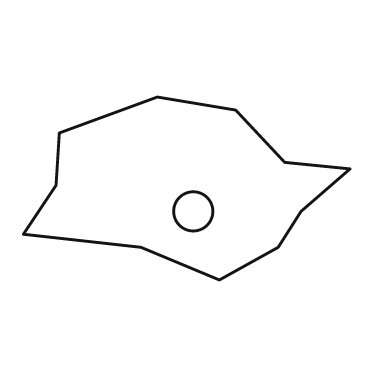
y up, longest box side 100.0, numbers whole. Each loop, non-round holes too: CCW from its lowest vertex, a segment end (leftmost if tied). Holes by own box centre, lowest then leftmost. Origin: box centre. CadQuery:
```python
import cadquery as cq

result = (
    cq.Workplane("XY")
    .moveTo(10.0, -28.0)
    .lineTo(28.0, -18.0)
    .lineTo(35.0, -7.0)
    .lineTo(50.0, 6.0)
    .lineTo(30.0, 8.0)
    .lineTo(15.0, 24.0)
    .lineTo(-9.0, 28.0)
    .lineTo(-39.0, 17.0)
    .lineTo(-40.0, 1.0)
    .lineTo(-50.0, -14.0)
    .lineTo(-14.0, -18.0)
    .close()
    .moveTo(2.0, -7.0)
    .circle(6.0)
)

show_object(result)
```